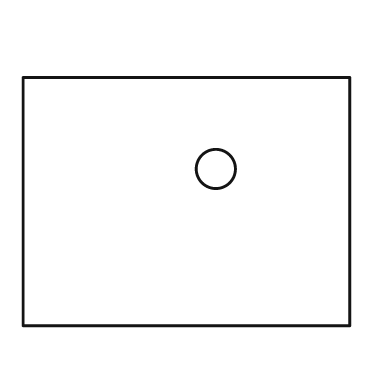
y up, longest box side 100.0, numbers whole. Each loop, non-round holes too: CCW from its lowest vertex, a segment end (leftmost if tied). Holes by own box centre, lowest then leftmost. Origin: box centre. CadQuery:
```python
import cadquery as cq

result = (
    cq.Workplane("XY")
    .moveTo(-50.0, -38.0)
    .lineTo(50.0, -38.0)
    .lineTo(50.0, 38.0)
    .lineTo(-50.0, 38.0)
    .close()
    .moveTo(9.0, 10.0)
    .circle(6.0)
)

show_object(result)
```